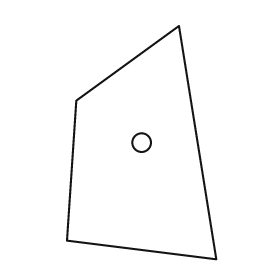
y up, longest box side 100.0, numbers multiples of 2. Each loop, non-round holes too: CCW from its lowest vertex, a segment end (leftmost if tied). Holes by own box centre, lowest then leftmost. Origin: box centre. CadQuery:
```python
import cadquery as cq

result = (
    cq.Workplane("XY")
    .moveTo(32.0, -50.0)
    .lineTo(16.0, 50.0)
    .lineTo(-28.0, 18.0)
    .lineTo(-32.0, -42.0)
    .close()
    .moveTo(0.0, 0.0)
    .circle(4.0)
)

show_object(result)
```